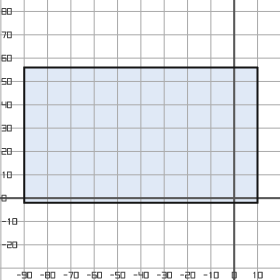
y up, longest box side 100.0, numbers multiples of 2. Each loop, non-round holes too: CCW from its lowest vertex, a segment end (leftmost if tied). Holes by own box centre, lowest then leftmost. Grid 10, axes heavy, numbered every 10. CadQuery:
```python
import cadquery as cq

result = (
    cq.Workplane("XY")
    .moveTo(-90.0, -2.0)
    .lineTo(10.0, -2.0)
    .lineTo(10.0, 56.0)
    .lineTo(-90.0, 56.0)
    .close()
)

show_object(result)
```